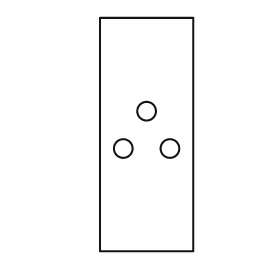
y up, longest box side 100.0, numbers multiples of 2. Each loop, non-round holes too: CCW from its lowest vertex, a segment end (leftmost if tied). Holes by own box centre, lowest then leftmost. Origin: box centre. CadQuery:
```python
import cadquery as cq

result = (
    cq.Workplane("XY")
    .moveTo(-20.0, -50.0)
    .lineTo(20.0, -50.0)
    .lineTo(20.0, 50.0)
    .lineTo(-20.0, 50.0)
    .close()
    .moveTo(-10.0, -6.0)
    .circle(4.0)
    .moveTo(10.0, -6.0)
    .circle(4.0)
    .moveTo(0.0, 10.0)
    .circle(4.0)
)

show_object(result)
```